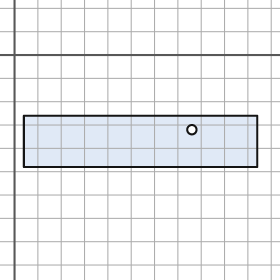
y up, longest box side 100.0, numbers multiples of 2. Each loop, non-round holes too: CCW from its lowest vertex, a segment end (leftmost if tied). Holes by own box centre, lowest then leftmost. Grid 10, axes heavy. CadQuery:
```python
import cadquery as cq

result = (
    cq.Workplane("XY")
    .moveTo(4.0, -48.0)
    .lineTo(104.0, -48.0)
    .lineTo(104.0, -26.0)
    .lineTo(4.0, -26.0)
    .close()
    .moveTo(76.0, -32.0)
    .circle(2.0)
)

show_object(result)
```